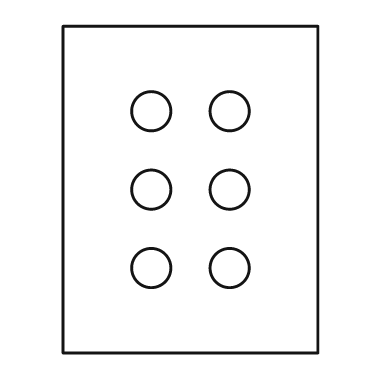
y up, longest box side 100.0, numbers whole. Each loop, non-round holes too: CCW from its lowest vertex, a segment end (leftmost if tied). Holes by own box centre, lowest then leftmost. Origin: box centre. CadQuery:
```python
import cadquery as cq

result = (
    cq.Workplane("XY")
    .moveTo(-39.0, -50.0)
    .lineTo(39.0, -50.0)
    .lineTo(39.0, 50.0)
    .lineTo(-39.0, 50.0)
    .close()
    .moveTo(-12.0, -24.0)
    .circle(6.0)
    .moveTo(12.0, -24.0)
    .circle(6.0)
    .moveTo(-12.0, 0.0)
    .circle(6.0)
    .moveTo(12.0, 0.0)
    .circle(6.0)
    .moveTo(-12.0, 24.0)
    .circle(6.0)
    .moveTo(12.0, 24.0)
    .circle(6.0)
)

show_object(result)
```